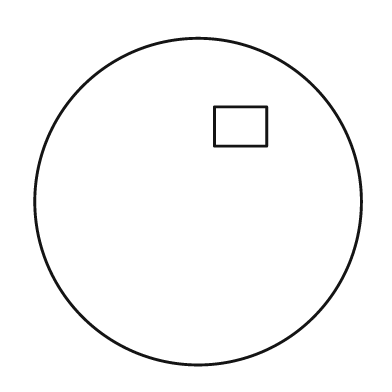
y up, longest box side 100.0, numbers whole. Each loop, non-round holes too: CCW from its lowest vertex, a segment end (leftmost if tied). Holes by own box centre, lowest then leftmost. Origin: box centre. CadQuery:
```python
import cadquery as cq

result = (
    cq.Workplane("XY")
    .moveTo(0.0, 0.0)
    .circle(50.0)
    .moveTo(5.0, 17.0)
    .lineTo(21.0, 17.0)
    .lineTo(21.0, 29.0)
    .lineTo(5.0, 29.0)
    .close()
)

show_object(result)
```